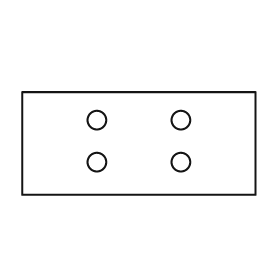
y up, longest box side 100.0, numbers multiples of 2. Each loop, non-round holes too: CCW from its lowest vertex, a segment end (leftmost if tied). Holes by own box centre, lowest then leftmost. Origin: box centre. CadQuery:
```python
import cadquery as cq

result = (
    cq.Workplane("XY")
    .moveTo(-50.0, -22.0)
    .lineTo(50.0, -22.0)
    .lineTo(50.0, 22.0)
    .lineTo(-50.0, 22.0)
    .close()
    .moveTo(-18.0, -8.0)
    .circle(4.0)
    .moveTo(18.0, -8.0)
    .circle(4.0)
    .moveTo(-18.0, 10.0)
    .circle(4.0)
    .moveTo(18.0, 10.0)
    .circle(4.0)
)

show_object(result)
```